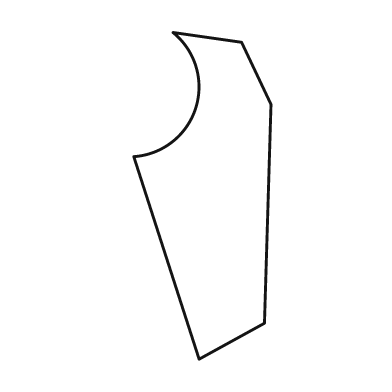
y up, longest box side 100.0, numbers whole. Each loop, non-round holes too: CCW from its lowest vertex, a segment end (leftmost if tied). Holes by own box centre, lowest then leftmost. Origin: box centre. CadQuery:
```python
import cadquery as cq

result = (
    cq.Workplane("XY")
    .moveTo(-1.0, -50.0)
    .lineTo(19.0, -39.0)
    .lineTo(21.0, 28.0)
    .lineTo(12.0, 47.0)
    .lineTo(-9.0, 50.0)
    .threePointArc((-2.0, 27.0), (-21.0, 12.0))
    .close()
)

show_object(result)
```